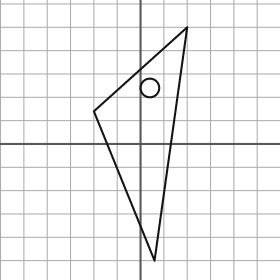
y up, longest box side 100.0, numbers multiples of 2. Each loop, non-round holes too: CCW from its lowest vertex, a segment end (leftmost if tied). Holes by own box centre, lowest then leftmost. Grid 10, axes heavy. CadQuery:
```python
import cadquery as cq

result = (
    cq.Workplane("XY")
    .moveTo(6.0, -50.0)
    .lineTo(20.0, 50.0)
    .lineTo(-20.0, 14.0)
    .close()
    .moveTo(4.0, 24.0)
    .circle(4.0)
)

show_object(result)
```